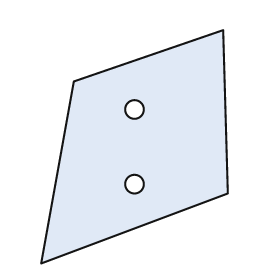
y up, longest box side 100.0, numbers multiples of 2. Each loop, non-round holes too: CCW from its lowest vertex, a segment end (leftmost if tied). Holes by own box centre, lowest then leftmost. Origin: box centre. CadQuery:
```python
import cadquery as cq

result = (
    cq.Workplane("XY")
    .moveTo(-40.0, -50.0)
    .lineTo(40.0, -20.0)
    .lineTo(38.0, 50.0)
    .lineTo(-26.0, 28.0)
    .close()
    .moveTo(0.0, -16.0)
    .circle(4.0)
    .moveTo(0.0, 16.0)
    .circle(4.0)
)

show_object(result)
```